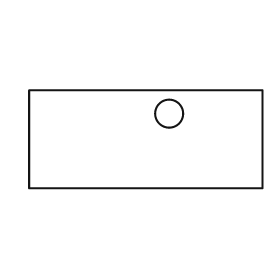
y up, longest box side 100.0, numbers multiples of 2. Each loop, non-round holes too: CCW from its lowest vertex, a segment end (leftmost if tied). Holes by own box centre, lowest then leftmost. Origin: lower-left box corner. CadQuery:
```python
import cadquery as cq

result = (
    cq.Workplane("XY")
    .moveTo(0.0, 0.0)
    .lineTo(100.0, 0.0)
    .lineTo(100.0, 42.0)
    .lineTo(0.0, 42.0)
    .close()
    .moveTo(60.0, 32.0)
    .circle(6.0)
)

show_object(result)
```